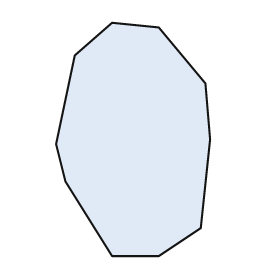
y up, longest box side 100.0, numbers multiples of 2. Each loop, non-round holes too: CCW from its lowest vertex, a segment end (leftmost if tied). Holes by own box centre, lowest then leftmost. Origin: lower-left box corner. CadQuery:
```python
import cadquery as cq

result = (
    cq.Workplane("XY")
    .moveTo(24.0, 0.0)
    .lineTo(44.0, 0.0)
    .lineTo(62.0, 12.0)
    .lineTo(66.0, 50.0)
    .lineTo(64.0, 74.0)
    .lineTo(44.0, 98.0)
    .lineTo(24.0, 100.0)
    .lineTo(8.0, 86.0)
    .lineTo(0.0, 48.0)
    .lineTo(4.0, 32.0)
    .close()
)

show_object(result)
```